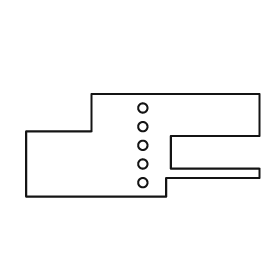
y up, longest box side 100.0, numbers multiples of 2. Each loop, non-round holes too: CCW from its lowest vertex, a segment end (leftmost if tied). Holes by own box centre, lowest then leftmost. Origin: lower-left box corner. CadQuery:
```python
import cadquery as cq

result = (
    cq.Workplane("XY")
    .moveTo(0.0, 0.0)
    .lineTo(60.0, 0.0)
    .lineTo(60.0, 8.0)
    .lineTo(100.0, 8.0)
    .lineTo(100.0, 12.0)
    .lineTo(62.0, 12.0)
    .lineTo(62.0, 26.0)
    .lineTo(100.0, 26.0)
    .lineTo(100.0, 44.0)
    .lineTo(28.0, 44.0)
    .lineTo(28.0, 28.0)
    .lineTo(0.0, 28.0)
    .close()
    .moveTo(50.0, 6.0)
    .circle(2.0)
    .moveTo(50.0, 14.0)
    .circle(2.0)
    .moveTo(50.0, 22.0)
    .circle(2.0)
    .moveTo(50.0, 30.0)
    .circle(2.0)
    .moveTo(50.0, 38.0)
    .circle(2.0)
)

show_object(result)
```